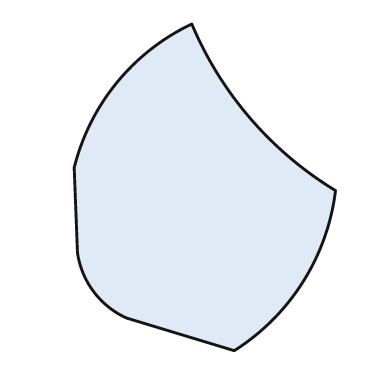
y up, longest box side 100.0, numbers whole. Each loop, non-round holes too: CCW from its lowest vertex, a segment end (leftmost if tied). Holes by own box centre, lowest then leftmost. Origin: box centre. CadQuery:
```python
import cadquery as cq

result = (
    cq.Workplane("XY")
    .moveTo(9.0, -50.0)
    .threePointArc((30.0, -29.0), (40.0, -1.0))
    .threePointArc((14.0, 21.0), (-4.0, 50.0))
    .threePointArc((-27.0, 32.0), (-40.0, 6.0))
    .lineTo(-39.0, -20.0)
    .threePointArc((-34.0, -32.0), (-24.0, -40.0))
    .close()
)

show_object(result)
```